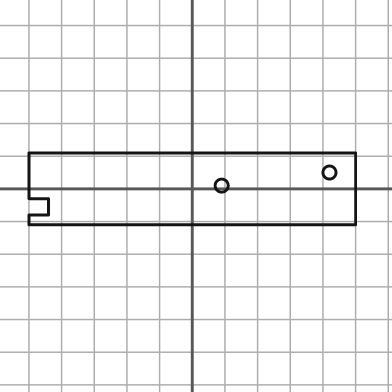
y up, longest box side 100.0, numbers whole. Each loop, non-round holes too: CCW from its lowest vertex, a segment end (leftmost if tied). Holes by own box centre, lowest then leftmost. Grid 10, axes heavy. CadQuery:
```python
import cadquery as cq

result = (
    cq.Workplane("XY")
    .moveTo(-50.0, -11.0)
    .lineTo(50.0, -11.0)
    .lineTo(50.0, 11.0)
    .lineTo(-50.0, 11.0)
    .lineTo(-50.0, -3.0)
    .lineTo(-44.0, -3.0)
    .lineTo(-44.0, -8.0)
    .lineTo(-50.0, -8.0)
    .close()
    .moveTo(9.0, 1.0)
    .circle(2.0)
    .moveTo(42.0, 5.0)
    .circle(2.0)
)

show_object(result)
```